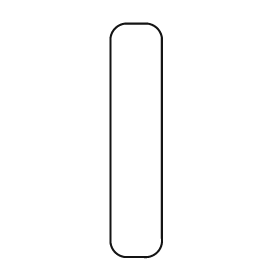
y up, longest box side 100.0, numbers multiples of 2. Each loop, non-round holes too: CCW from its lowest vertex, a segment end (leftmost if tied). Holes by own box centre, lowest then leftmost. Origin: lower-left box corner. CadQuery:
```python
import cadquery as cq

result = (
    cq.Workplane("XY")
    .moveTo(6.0, 0.0)
    .lineTo(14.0, 0.0)
    .threePointArc((20.0, 2.0), (22.0, 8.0))
    .lineTo(22.0, 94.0)
    .threePointArc((20.0, 98.0), (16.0, 100.0))
    .lineTo(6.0, 100.0)
    .threePointArc((2.0, 98.0), (0.0, 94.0))
    .lineTo(0.0, 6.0)
    .threePointArc((2.0, 2.0), (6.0, 0.0))
    .close()
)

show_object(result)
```